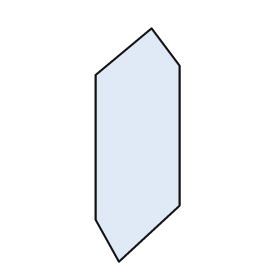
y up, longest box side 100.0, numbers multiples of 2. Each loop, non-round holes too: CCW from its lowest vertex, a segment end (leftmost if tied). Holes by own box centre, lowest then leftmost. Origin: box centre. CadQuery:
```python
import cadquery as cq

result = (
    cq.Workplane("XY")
    .moveTo(-8.0, -50.0)
    .lineTo(18.0, -26.0)
    .lineTo(18.0, 34.0)
    .lineTo(6.0, 50.0)
    .lineTo(-18.0, 30.0)
    .lineTo(-18.0, -32.0)
    .close()
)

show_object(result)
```